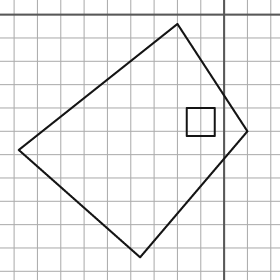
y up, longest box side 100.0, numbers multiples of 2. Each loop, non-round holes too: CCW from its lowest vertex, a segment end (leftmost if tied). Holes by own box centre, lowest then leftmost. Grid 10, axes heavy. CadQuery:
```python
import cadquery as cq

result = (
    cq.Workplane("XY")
    .moveTo(-36.0, -104.0)
    .lineTo(10.0, -50.0)
    .lineTo(-20.0, -4.0)
    .lineTo(-88.0, -58.0)
    .close()
    .moveTo(-16.0, -52.0)
    .lineTo(-4.0, -52.0)
    .lineTo(-4.0, -40.0)
    .lineTo(-16.0, -40.0)
    .close()
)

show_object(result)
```